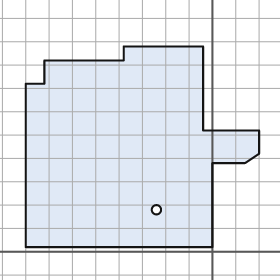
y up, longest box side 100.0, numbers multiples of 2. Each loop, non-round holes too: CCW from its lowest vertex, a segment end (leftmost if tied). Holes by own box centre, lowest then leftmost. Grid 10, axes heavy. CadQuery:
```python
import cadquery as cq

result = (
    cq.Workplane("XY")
    .moveTo(-80.0, 2.0)
    .lineTo(0.0, 2.0)
    .lineTo(0.0, 38.0)
    .lineTo(14.0, 38.0)
    .lineTo(20.0, 42.0)
    .lineTo(20.0, 52.0)
    .lineTo(-4.0, 52.0)
    .lineTo(-4.0, 88.0)
    .lineTo(-38.0, 88.0)
    .lineTo(-38.0, 82.0)
    .lineTo(-72.0, 82.0)
    .lineTo(-72.0, 72.0)
    .lineTo(-80.0, 72.0)
    .close()
    .moveTo(-24.0, 18.0)
    .circle(2.0)
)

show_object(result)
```